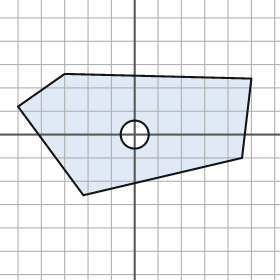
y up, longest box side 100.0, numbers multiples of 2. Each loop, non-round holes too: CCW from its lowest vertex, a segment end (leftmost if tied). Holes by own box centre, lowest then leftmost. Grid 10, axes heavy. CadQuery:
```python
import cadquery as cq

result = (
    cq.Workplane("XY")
    .moveTo(-22.0, -26.0)
    .lineTo(46.0, -10.0)
    .lineTo(50.0, 24.0)
    .lineTo(-30.0, 26.0)
    .lineTo(-50.0, 12.0)
    .close()
    .moveTo(0.0, 0.0)
    .circle(6.0)
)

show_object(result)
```